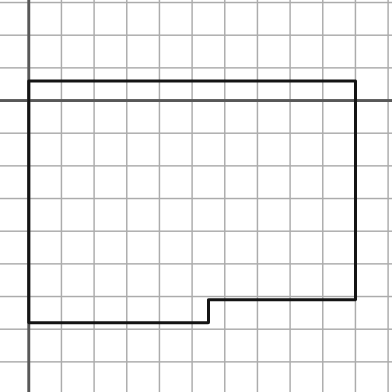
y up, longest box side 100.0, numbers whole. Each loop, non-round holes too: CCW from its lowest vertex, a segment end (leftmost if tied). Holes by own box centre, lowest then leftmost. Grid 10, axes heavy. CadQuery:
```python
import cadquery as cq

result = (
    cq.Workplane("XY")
    .moveTo(0.0, -68.0)
    .lineTo(55.0, -68.0)
    .lineTo(55.0, -61.0)
    .lineTo(100.0, -61.0)
    .lineTo(100.0, 6.0)
    .lineTo(0.0, 6.0)
    .close()
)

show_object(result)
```